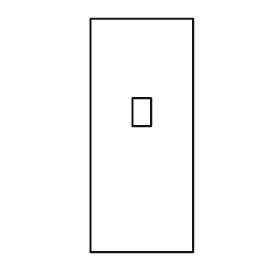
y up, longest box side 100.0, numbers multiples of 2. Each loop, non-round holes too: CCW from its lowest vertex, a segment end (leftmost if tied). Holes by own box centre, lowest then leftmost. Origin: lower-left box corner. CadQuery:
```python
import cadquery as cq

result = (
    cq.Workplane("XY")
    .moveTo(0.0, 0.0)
    .lineTo(44.0, 0.0)
    .lineTo(44.0, 100.0)
    .lineTo(0.0, 100.0)
    .close()
    .moveTo(18.0, 54.0)
    .lineTo(26.0, 54.0)
    .lineTo(26.0, 66.0)
    .lineTo(18.0, 66.0)
    .close()
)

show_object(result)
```